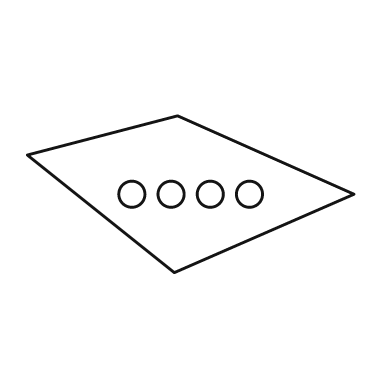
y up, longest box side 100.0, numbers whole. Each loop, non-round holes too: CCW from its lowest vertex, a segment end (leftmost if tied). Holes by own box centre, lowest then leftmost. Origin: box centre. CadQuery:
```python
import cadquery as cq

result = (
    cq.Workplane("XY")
    .moveTo(-5.0, -24.0)
    .lineTo(50.0, 0.0)
    .lineTo(-4.0, 24.0)
    .lineTo(-50.0, 12.0)
    .close()
    .moveTo(-18.0, 0.0)
    .circle(4.0)
    .moveTo(-6.0, 0.0)
    .circle(4.0)
    .moveTo(6.0, 0.0)
    .circle(4.0)
    .moveTo(18.0, 0.0)
    .circle(4.0)
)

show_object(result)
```